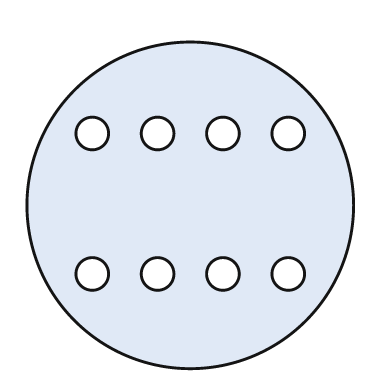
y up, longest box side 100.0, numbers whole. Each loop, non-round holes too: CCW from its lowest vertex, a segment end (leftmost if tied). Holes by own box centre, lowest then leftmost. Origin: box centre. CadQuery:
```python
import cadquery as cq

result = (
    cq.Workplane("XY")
    .moveTo(0.0, 0.0)
    .circle(50.0)
    .moveTo(-30.0, -21.0)
    .circle(5.0)
    .moveTo(-10.0, -21.0)
    .circle(5.0)
    .moveTo(10.0, -21.0)
    .circle(5.0)
    .moveTo(30.0, -21.0)
    .circle(5.0)
    .moveTo(-30.0, 22.0)
    .circle(5.0)
    .moveTo(-10.0, 22.0)
    .circle(5.0)
    .moveTo(10.0, 22.0)
    .circle(5.0)
    .moveTo(30.0, 22.0)
    .circle(5.0)
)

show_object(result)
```